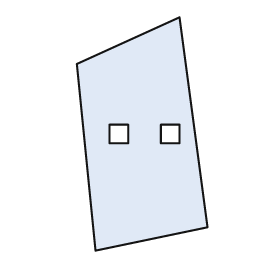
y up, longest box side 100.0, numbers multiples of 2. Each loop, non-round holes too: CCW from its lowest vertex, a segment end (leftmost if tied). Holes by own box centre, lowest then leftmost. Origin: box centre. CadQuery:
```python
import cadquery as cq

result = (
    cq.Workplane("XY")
    .moveTo(-20.0, -50.0)
    .lineTo(28.0, -40.0)
    .lineTo(16.0, 50.0)
    .lineTo(-28.0, 30.0)
    .close()
    .moveTo(-14.0, -4.0)
    .lineTo(-6.0, -4.0)
    .lineTo(-6.0, 4.0)
    .lineTo(-14.0, 4.0)
    .close()
    .moveTo(8.0, -4.0)
    .lineTo(16.0, -4.0)
    .lineTo(16.0, 4.0)
    .lineTo(8.0, 4.0)
    .close()
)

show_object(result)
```